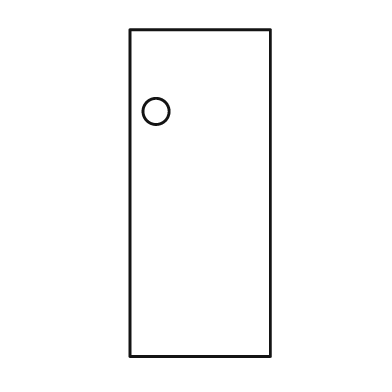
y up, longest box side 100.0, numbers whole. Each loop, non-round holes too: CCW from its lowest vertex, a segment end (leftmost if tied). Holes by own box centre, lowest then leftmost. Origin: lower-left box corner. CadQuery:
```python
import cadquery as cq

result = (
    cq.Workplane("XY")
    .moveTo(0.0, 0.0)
    .lineTo(43.0, 0.0)
    .lineTo(43.0, 100.0)
    .lineTo(0.0, 100.0)
    .close()
    .moveTo(8.0, 75.0)
    .circle(4.0)
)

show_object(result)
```